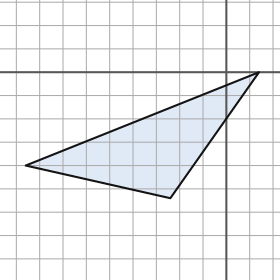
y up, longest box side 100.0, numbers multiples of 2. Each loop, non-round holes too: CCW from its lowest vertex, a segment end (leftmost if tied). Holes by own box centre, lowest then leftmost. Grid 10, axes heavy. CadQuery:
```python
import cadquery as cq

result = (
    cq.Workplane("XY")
    .moveTo(-24.0, -54.0)
    .lineTo(14.0, 0.0)
    .lineTo(-86.0, -40.0)
    .close()
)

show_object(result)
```